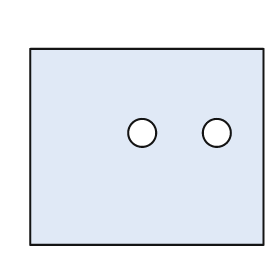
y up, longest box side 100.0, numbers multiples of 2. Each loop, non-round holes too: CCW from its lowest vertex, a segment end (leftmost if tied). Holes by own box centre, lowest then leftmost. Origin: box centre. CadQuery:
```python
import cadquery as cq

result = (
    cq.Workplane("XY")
    .moveTo(-50.0, -42.0)
    .lineTo(50.0, -42.0)
    .lineTo(50.0, 42.0)
    .lineTo(-50.0, 42.0)
    .close()
    .moveTo(-2.0, 6.0)
    .circle(6.0)
    .moveTo(30.0, 6.0)
    .circle(6.0)
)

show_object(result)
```